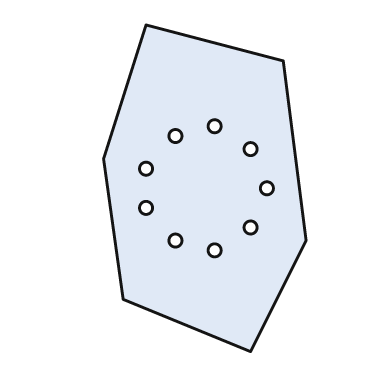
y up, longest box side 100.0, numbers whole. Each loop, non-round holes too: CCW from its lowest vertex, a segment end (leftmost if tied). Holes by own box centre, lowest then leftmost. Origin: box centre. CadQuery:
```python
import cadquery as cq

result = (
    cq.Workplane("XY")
    .moveTo(14.0, -50.0)
    .lineTo(31.0, -16.0)
    .lineTo(24.0, 39.0)
    .lineTo(-18.0, 50.0)
    .lineTo(-31.0, 9.0)
    .lineTo(-25.0, -34.0)
    .close()
    .moveTo(3.0, -19.0)
    .circle(2.0)
    .moveTo(-9.0, -16.0)
    .circle(2.0)
    .moveTo(14.0, -12.0)
    .circle(2.0)
    .moveTo(-18.0, -6.0)
    .circle(2.0)
    .moveTo(19.0, 0.0)
    .circle(2.0)
    .moveTo(-18.0, 6.0)
    .circle(2.0)
    .moveTo(14.0, 12.0)
    .circle(2.0)
    .moveTo(-9.0, 16.0)
    .circle(2.0)
    .moveTo(3.0, 19.0)
    .circle(2.0)
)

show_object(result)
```